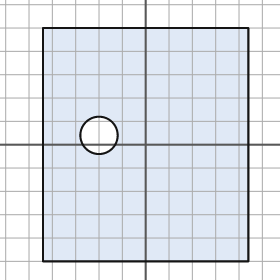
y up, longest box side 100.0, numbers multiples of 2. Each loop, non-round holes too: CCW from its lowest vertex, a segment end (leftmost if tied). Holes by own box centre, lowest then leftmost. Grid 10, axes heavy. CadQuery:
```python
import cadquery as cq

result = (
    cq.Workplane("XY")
    .moveTo(-44.0, -50.0)
    .lineTo(44.0, -50.0)
    .lineTo(44.0, 50.0)
    .lineTo(-44.0, 50.0)
    .close()
    .moveTo(-20.0, 4.0)
    .circle(8.0)
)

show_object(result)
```